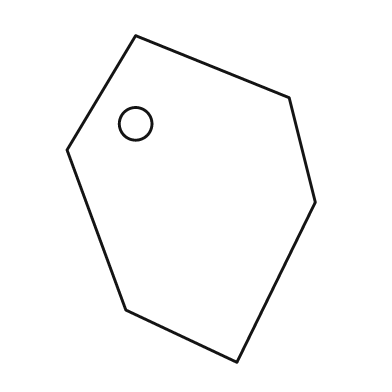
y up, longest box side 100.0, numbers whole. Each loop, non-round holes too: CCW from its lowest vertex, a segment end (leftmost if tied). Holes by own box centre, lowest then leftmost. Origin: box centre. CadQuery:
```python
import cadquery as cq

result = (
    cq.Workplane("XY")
    .moveTo(14.0, -50.0)
    .lineTo(38.0, -1.0)
    .lineTo(30.0, 31.0)
    .lineTo(-17.0, 50.0)
    .lineTo(-38.0, 15.0)
    .lineTo(-20.0, -34.0)
    .close()
    .moveTo(-17.0, 23.0)
    .circle(5.0)
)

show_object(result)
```